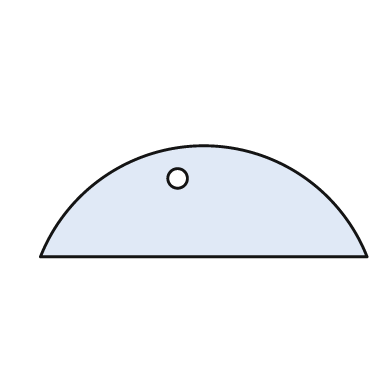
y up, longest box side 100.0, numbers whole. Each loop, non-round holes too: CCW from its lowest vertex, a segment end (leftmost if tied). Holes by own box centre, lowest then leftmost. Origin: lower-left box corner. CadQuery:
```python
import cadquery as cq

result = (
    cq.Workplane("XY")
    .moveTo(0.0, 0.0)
    .lineTo(100.0, 0.0)
    .threePointArc((50.0, 34.0), (0.0, 0.0))
    .close()
    .moveTo(42.0, 24.0)
    .circle(3.0)
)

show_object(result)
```